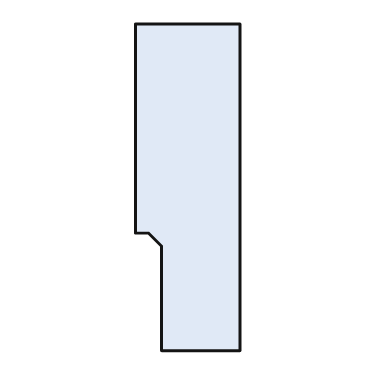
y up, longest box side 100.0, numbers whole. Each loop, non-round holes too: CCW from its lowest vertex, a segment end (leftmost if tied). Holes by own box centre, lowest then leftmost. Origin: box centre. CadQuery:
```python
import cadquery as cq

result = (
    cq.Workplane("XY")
    .moveTo(-8.0, -50.0)
    .lineTo(16.0, -50.0)
    .lineTo(16.0, 50.0)
    .lineTo(-16.0, 50.0)
    .lineTo(-16.0, -14.0)
    .lineTo(-12.0, -14.0)
    .lineTo(-8.0, -18.0)
    .close()
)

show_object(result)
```